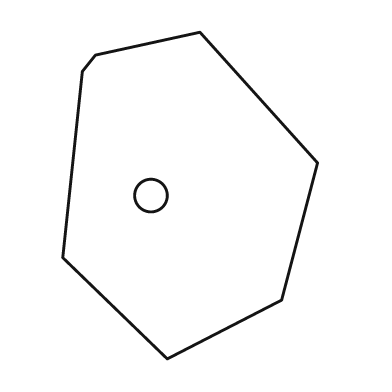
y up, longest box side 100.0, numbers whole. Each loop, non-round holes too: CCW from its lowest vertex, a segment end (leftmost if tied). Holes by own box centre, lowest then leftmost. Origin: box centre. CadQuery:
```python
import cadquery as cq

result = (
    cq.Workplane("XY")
    .moveTo(-7.0, -50.0)
    .lineTo(28.0, -32.0)
    .lineTo(39.0, 10.0)
    .lineTo(3.0, 50.0)
    .lineTo(-29.0, 43.0)
    .lineTo(-33.0, 38.0)
    .lineTo(-39.0, -19.0)
    .close()
    .moveTo(-12.0, 0.0)
    .circle(5.0)
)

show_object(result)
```